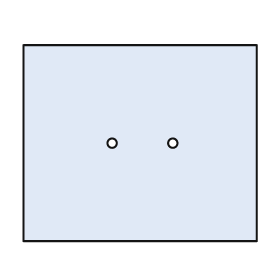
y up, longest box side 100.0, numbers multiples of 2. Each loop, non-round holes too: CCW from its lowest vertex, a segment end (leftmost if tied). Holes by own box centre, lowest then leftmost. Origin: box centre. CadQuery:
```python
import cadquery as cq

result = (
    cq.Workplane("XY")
    .moveTo(-50.0, -42.0)
    .lineTo(50.0, -42.0)
    .lineTo(50.0, 42.0)
    .lineTo(-50.0, 42.0)
    .close()
    .moveTo(-12.0, 0.0)
    .circle(2.0)
    .moveTo(14.0, 0.0)
    .circle(2.0)
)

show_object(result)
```